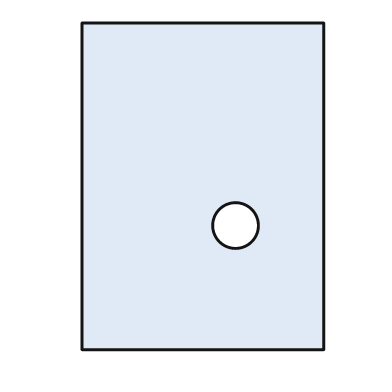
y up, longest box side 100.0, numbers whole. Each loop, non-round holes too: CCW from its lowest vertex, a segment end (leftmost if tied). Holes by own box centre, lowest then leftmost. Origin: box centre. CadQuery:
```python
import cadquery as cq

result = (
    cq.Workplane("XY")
    .moveTo(-37.0, -50.0)
    .lineTo(37.0, -50.0)
    .lineTo(37.0, 50.0)
    .lineTo(-37.0, 50.0)
    .close()
    .moveTo(10.0, -12.0)
    .circle(7.0)
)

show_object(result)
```